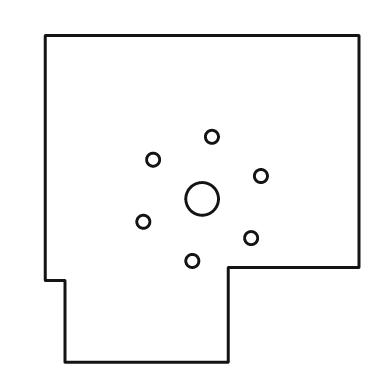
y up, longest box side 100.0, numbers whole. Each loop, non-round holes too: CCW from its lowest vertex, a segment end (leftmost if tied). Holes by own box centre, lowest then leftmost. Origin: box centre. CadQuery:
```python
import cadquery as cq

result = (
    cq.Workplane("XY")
    .moveTo(-42.0, -50.0)
    .lineTo(8.0, -50.0)
    .lineTo(8.0, -21.0)
    .lineTo(48.0, -21.0)
    .lineTo(48.0, 50.0)
    .lineTo(-48.0, 50.0)
    .lineTo(-48.0, -25.0)
    .lineTo(-42.0, -25.0)
    .close()
    .moveTo(-3.0, -19.0)
    .circle(2.0)
    .moveTo(15.0, -12.0)
    .circle(2.0)
    .moveTo(-18.0, -7.0)
    .circle(2.0)
    .moveTo(0.0, 0.0)
    .circle(5.0)
    .moveTo(18.0, 7.0)
    .circle(2.0)
    .moveTo(-15.0, 12.0)
    .circle(2.0)
    .moveTo(3.0, 19.0)
    .circle(2.0)
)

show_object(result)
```